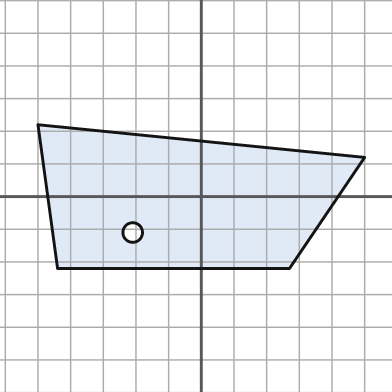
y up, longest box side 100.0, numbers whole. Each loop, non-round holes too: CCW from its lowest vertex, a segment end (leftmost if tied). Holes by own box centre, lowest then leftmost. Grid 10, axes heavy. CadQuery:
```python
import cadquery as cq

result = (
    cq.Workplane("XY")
    .moveTo(-44.0, -22.0)
    .lineTo(27.0, -22.0)
    .lineTo(50.0, 12.0)
    .lineTo(-50.0, 22.0)
    .close()
    .moveTo(-21.0, -11.0)
    .circle(3.0)
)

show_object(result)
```